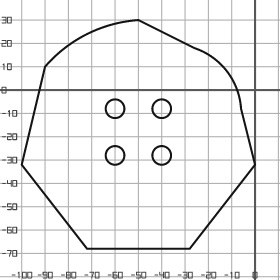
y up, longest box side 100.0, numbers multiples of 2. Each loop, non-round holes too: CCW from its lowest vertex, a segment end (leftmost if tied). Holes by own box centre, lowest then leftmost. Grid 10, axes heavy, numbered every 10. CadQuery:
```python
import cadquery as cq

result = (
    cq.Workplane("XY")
    .moveTo(-72.0, -68.0)
    .lineTo(-28.0, -68.0)
    .lineTo(0.0, -32.0)
    .lineTo(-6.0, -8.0)
    .threePointArc((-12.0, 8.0), (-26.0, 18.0))
    .lineTo(-50.0, 30.0)
    .threePointArc((-72.0, 24.0), (-90.0, 10.0))
    .lineTo(-100.0, -32.0)
    .close()
    .moveTo(-60.0, -28.0)
    .circle(4.0)
    .moveTo(-40.0, -28.0)
    .circle(4.0)
    .moveTo(-60.0, -8.0)
    .circle(4.0)
    .moveTo(-40.0, -8.0)
    .circle(4.0)
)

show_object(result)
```